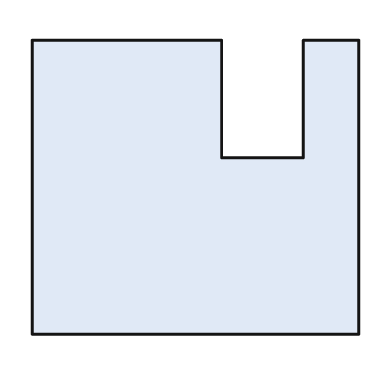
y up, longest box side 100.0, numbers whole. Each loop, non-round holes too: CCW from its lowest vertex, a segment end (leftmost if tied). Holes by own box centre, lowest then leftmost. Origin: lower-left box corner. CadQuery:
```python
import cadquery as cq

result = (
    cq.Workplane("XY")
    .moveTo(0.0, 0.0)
    .lineTo(100.0, 0.0)
    .lineTo(100.0, 90.0)
    .lineTo(83.0, 90.0)
    .lineTo(83.0, 54.0)
    .lineTo(58.0, 54.0)
    .lineTo(58.0, 90.0)
    .lineTo(0.0, 90.0)
    .close()
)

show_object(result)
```